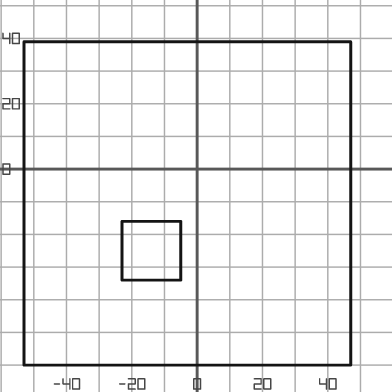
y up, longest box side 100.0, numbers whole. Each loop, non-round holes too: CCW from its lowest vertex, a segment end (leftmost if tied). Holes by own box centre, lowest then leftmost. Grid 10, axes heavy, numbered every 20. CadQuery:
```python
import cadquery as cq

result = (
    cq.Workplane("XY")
    .moveTo(-53.0, -60.0)
    .lineTo(47.0, -60.0)
    .lineTo(47.0, 39.0)
    .lineTo(-53.0, 39.0)
    .close()
    .moveTo(-23.0, -34.0)
    .lineTo(-5.0, -34.0)
    .lineTo(-5.0, -16.0)
    .lineTo(-23.0, -16.0)
    .close()
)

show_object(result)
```